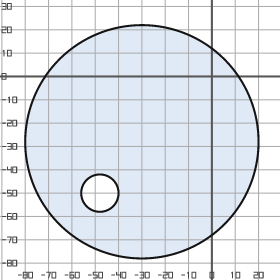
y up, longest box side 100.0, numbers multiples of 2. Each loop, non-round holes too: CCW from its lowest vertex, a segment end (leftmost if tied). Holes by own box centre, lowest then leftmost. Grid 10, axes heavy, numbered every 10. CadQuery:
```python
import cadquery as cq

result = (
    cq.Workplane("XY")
    .moveTo(-30.0, -28.0)
    .circle(50.0)
    .moveTo(-48.0, -50.0)
    .circle(8.0)
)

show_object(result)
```